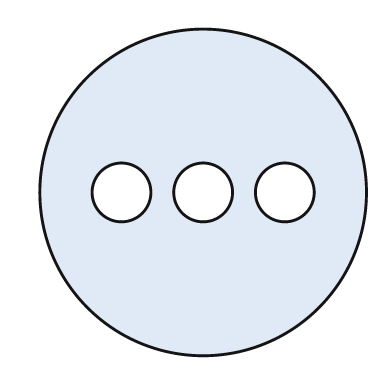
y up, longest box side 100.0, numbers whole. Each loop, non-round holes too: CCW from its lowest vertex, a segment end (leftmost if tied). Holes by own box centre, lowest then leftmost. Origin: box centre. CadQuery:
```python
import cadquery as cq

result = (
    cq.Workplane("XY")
    .moveTo(0.0, 0.0)
    .circle(50.0)
    .moveTo(-25.0, 0.0)
    .circle(9.0)
    .moveTo(0.0, 0.0)
    .circle(9.0)
    .moveTo(25.0, 0.0)
    .circle(9.0)
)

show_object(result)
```